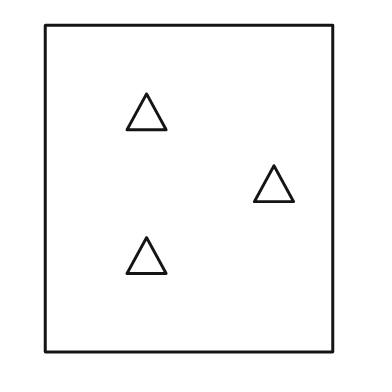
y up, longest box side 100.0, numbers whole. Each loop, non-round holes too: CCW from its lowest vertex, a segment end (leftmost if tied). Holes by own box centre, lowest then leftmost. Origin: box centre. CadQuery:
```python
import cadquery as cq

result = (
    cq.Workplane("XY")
    .moveTo(-44.0, -50.0)
    .lineTo(44.0, -50.0)
    .lineTo(44.0, 50.0)
    .lineTo(-44.0, 50.0)
    .close()
    .moveTo(-19.0, -26.0)
    .lineTo(-7.0, -26.0)
    .lineTo(-13.0, -15.0)
    .close()
    .moveTo(20.0, -4.0)
    .lineTo(32.0, -4.0)
    .lineTo(26.0, 7.0)
    .close()
    .moveTo(-19.0, 18.0)
    .lineTo(-7.0, 18.0)
    .lineTo(-13.0, 29.0)
    .close()
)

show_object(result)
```